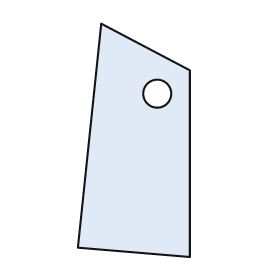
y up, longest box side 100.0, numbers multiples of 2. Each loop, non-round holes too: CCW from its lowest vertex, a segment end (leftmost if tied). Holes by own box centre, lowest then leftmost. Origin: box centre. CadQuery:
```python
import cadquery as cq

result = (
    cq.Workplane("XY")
    .moveTo(24.0, -50.0)
    .lineTo(24.0, 30.0)
    .lineTo(-14.0, 50.0)
    .lineTo(-24.0, -46.0)
    .close()
    .moveTo(10.0, 20.0)
    .circle(6.0)
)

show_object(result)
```